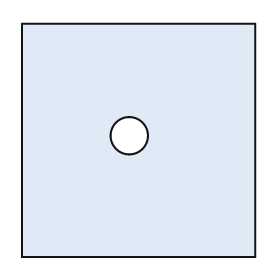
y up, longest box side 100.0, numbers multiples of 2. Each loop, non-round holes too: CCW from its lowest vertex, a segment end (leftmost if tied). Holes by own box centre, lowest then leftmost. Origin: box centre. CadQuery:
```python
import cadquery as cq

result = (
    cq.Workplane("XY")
    .moveTo(-50.0, -50.0)
    .lineTo(50.0, -50.0)
    .lineTo(50.0, 50.0)
    .lineTo(-50.0, 50.0)
    .close()
    .moveTo(-4.0, 2.0)
    .circle(8.0)
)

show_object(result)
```